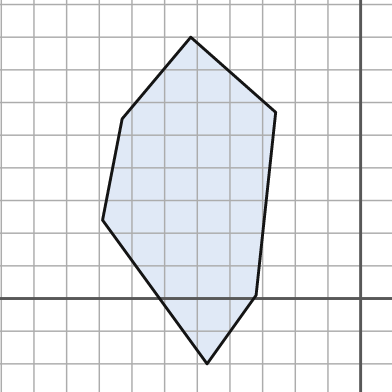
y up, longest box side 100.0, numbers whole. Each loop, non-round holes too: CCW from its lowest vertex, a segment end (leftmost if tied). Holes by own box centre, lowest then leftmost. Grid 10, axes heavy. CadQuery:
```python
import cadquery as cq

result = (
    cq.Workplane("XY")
    .moveTo(-47.0, -20.0)
    .lineTo(-32.0, 1.0)
    .lineTo(-26.0, 57.0)
    .lineTo(-52.0, 80.0)
    .lineTo(-73.0, 55.0)
    .lineTo(-79.0, 24.0)
    .close()
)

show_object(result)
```